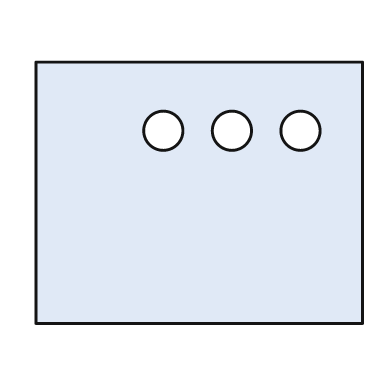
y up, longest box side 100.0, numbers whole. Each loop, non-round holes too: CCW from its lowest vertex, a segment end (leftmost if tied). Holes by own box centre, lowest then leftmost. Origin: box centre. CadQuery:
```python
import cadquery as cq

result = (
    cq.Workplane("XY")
    .moveTo(-50.0, -40.0)
    .lineTo(50.0, -40.0)
    .lineTo(50.0, 40.0)
    .lineTo(-50.0, 40.0)
    .close()
    .moveTo(-11.0, 19.0)
    .circle(6.0)
    .moveTo(10.0, 19.0)
    .circle(6.0)
    .moveTo(31.0, 19.0)
    .circle(6.0)
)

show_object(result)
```